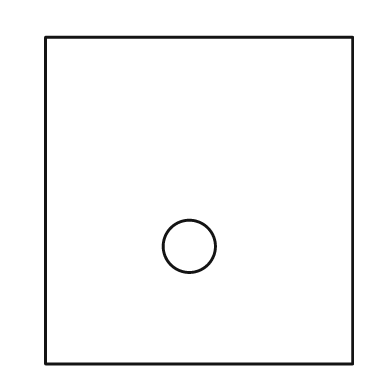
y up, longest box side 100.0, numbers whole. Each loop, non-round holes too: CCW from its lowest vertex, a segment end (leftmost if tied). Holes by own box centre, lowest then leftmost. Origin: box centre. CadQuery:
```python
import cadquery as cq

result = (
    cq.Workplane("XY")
    .moveTo(-47.0, -50.0)
    .lineTo(47.0, -50.0)
    .lineTo(47.0, 50.0)
    .lineTo(-47.0, 50.0)
    .close()
    .moveTo(-3.0, -14.0)
    .circle(8.0)
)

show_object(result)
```